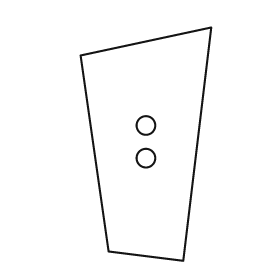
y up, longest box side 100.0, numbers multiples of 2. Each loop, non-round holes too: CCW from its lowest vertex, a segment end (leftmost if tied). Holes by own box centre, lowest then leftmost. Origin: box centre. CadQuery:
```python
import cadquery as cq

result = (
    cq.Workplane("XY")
    .moveTo(16.0, -50.0)
    .lineTo(28.0, 50.0)
    .lineTo(-28.0, 38.0)
    .lineTo(-16.0, -46.0)
    .close()
    .moveTo(0.0, -6.0)
    .circle(4.0)
    .moveTo(0.0, 8.0)
    .circle(4.0)
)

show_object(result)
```